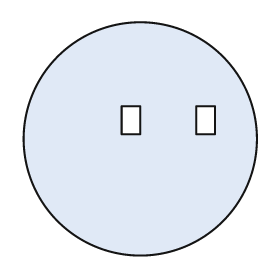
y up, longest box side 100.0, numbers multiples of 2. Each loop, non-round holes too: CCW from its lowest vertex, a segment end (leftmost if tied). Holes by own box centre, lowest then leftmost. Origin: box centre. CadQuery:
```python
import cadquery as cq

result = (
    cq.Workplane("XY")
    .moveTo(0.0, 0.0)
    .circle(50.0)
    .moveTo(-8.0, 2.0)
    .lineTo(0.0, 2.0)
    .lineTo(0.0, 14.0)
    .lineTo(-8.0, 14.0)
    .close()
    .moveTo(24.0, 2.0)
    .lineTo(32.0, 2.0)
    .lineTo(32.0, 14.0)
    .lineTo(24.0, 14.0)
    .close()
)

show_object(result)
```